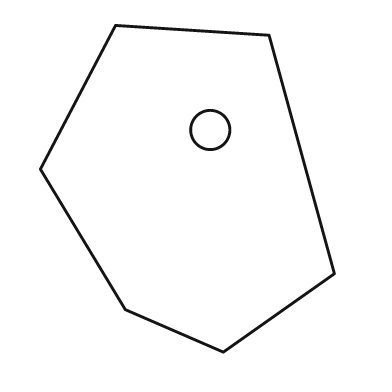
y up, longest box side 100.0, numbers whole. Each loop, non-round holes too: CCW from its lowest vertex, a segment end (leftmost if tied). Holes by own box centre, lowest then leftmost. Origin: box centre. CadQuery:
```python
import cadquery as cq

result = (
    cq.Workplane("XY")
    .moveTo(11.0, -50.0)
    .lineTo(45.0, -26.0)
    .lineTo(25.0, 47.0)
    .lineTo(-22.0, 50.0)
    .lineTo(-45.0, 6.0)
    .lineTo(-19.0, -37.0)
    .close()
    .moveTo(7.0, 18.0)
    .circle(6.0)
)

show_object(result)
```